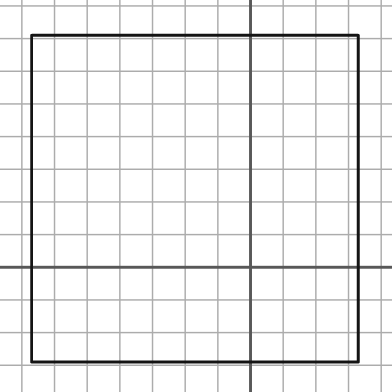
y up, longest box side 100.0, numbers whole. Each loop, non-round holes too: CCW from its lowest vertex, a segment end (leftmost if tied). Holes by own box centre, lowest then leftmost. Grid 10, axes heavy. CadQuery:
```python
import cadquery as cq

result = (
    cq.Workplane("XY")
    .moveTo(-67.0, -29.0)
    .lineTo(33.0, -29.0)
    .lineTo(33.0, 71.0)
    .lineTo(-67.0, 71.0)
    .close()
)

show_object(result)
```